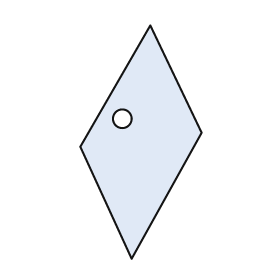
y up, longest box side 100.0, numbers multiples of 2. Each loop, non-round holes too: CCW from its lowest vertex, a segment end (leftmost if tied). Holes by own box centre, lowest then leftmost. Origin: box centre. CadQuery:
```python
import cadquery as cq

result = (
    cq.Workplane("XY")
    .moveTo(-4.0, -50.0)
    .lineTo(26.0, 4.0)
    .lineTo(4.0, 50.0)
    .lineTo(-26.0, -2.0)
    .close()
    .moveTo(-8.0, 10.0)
    .circle(4.0)
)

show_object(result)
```